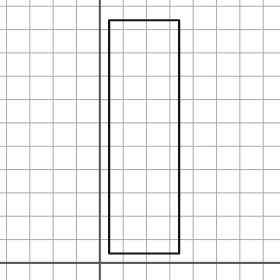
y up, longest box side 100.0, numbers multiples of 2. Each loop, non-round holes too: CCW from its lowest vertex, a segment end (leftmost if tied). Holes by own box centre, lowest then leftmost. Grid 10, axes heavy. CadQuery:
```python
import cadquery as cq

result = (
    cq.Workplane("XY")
    .moveTo(4.0, 4.0)
    .lineTo(34.0, 4.0)
    .lineTo(34.0, 104.0)
    .lineTo(4.0, 104.0)
    .close()
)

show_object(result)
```